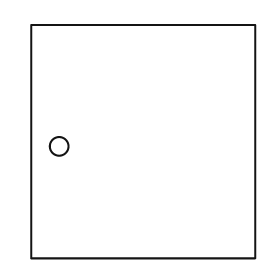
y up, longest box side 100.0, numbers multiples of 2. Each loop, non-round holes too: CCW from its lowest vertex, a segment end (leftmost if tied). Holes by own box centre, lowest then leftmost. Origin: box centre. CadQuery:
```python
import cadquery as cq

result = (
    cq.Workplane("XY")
    .moveTo(-48.0, -50.0)
    .lineTo(48.0, -50.0)
    .lineTo(48.0, 50.0)
    .lineTo(-48.0, 50.0)
    .close()
    .moveTo(-36.0, -2.0)
    .circle(4.0)
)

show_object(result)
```